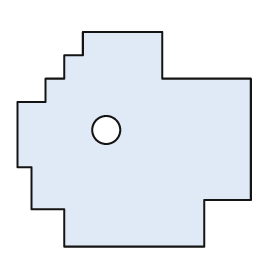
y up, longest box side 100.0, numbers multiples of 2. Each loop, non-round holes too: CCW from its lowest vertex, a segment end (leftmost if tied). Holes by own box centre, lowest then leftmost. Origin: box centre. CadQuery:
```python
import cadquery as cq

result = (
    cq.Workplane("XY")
    .moveTo(-30.0, -46.0)
    .lineTo(30.0, -46.0)
    .lineTo(30.0, -26.0)
    .lineTo(50.0, -26.0)
    .lineTo(50.0, 26.0)
    .lineTo(12.0, 26.0)
    .lineTo(12.0, 46.0)
    .lineTo(-22.0, 46.0)
    .lineTo(-22.0, 36.0)
    .lineTo(-30.0, 36.0)
    .lineTo(-30.0, 26.0)
    .lineTo(-38.0, 26.0)
    .lineTo(-38.0, 16.0)
    .lineTo(-50.0, 16.0)
    .lineTo(-50.0, -12.0)
    .lineTo(-44.0, -12.0)
    .lineTo(-44.0, -30.0)
    .lineTo(-30.0, -30.0)
    .close()
    .moveTo(-12.0, 4.0)
    .circle(6.0)
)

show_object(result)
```